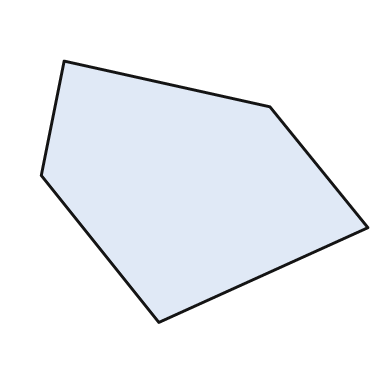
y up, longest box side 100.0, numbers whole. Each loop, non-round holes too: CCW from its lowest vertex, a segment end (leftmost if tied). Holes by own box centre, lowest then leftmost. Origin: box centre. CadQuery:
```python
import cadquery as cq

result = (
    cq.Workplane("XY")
    .moveTo(-14.0, -40.0)
    .lineTo(50.0, -11.0)
    .lineTo(20.0, 26.0)
    .lineTo(-43.0, 40.0)
    .lineTo(-50.0, 5.0)
    .close()
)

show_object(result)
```